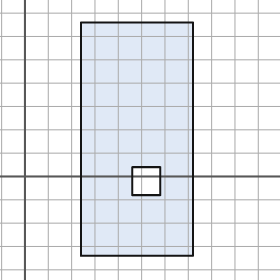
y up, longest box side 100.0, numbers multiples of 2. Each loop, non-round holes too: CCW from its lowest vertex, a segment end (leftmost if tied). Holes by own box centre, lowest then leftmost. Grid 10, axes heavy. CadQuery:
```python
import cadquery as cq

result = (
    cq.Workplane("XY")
    .moveTo(24.0, -34.0)
    .lineTo(72.0, -34.0)
    .lineTo(72.0, 66.0)
    .lineTo(24.0, 66.0)
    .close()
    .moveTo(46.0, -8.0)
    .lineTo(58.0, -8.0)
    .lineTo(58.0, 4.0)
    .lineTo(46.0, 4.0)
    .close()
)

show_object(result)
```